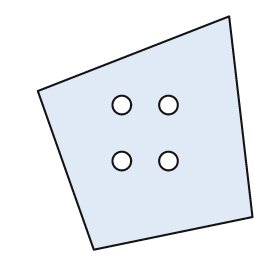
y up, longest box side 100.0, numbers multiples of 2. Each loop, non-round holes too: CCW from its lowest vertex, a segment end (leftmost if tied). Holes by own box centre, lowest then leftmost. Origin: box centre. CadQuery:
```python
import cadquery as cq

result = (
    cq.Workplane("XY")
    .moveTo(-22.0, -50.0)
    .lineTo(46.0, -36.0)
    .lineTo(36.0, 50.0)
    .lineTo(-46.0, 18.0)
    .close()
    .moveTo(-10.0, -12.0)
    .circle(4.0)
    .moveTo(10.0, -12.0)
    .circle(4.0)
    .moveTo(-10.0, 12.0)
    .circle(4.0)
    .moveTo(10.0, 12.0)
    .circle(4.0)
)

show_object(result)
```